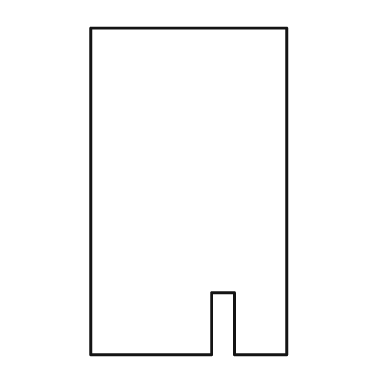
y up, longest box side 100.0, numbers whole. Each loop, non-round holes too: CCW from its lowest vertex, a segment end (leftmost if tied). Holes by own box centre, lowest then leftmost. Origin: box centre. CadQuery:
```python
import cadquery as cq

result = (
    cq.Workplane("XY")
    .moveTo(-30.0, -50.0)
    .lineTo(7.0, -50.0)
    .lineTo(7.0, -31.0)
    .lineTo(14.0, -31.0)
    .lineTo(14.0, -50.0)
    .lineTo(30.0, -50.0)
    .lineTo(30.0, 50.0)
    .lineTo(-30.0, 50.0)
    .close()
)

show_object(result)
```